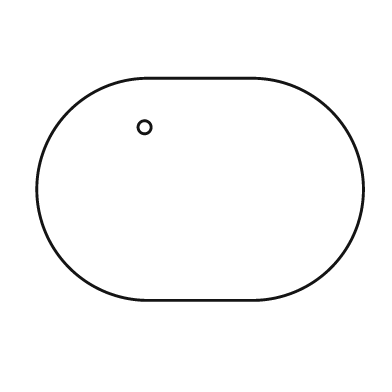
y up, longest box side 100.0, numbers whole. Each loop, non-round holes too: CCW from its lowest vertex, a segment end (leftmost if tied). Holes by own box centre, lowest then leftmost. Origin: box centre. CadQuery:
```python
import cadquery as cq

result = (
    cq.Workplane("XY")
    .moveTo(-16.0, -34.0)
    .lineTo(16.0, -34.0)
    .threePointArc((50.0, 0.0), (16.0, 34.0))
    .lineTo(-16.0, 34.0)
    .threePointArc((-50.0, 0.0), (-16.0, -34.0))
    .close()
    .moveTo(-17.0, 19.0)
    .circle(2.0)
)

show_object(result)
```